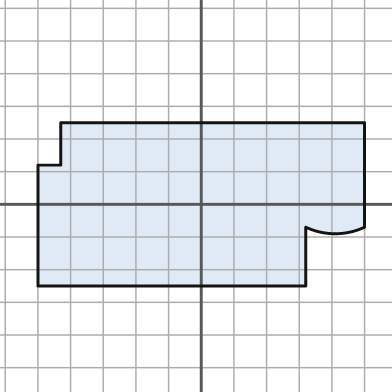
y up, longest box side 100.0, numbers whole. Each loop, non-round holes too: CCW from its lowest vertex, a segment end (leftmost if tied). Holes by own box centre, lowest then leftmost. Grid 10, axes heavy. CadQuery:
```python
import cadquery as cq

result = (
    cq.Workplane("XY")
    .moveTo(-50.0, -25.0)
    .lineTo(32.0, -25.0)
    .lineTo(32.0, -7.0)
    .threePointArc((41.0, -9.0), (50.0, -7.0))
    .lineTo(50.0, 25.0)
    .lineTo(-43.0, 25.0)
    .lineTo(-43.0, 12.0)
    .lineTo(-50.0, 12.0)
    .close()
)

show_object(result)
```